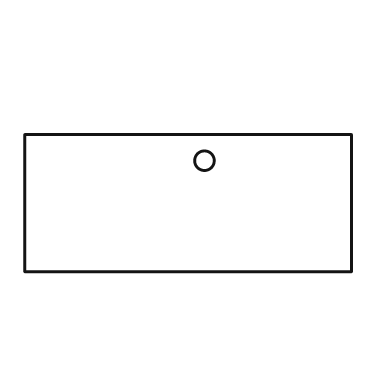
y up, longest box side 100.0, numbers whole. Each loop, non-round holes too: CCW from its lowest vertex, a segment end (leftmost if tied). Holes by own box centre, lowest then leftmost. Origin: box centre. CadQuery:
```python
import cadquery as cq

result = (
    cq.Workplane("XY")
    .moveTo(-50.0, -21.0)
    .lineTo(50.0, -21.0)
    .lineTo(50.0, 21.0)
    .lineTo(-50.0, 21.0)
    .close()
    .moveTo(5.0, 13.0)
    .circle(3.0)
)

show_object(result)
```